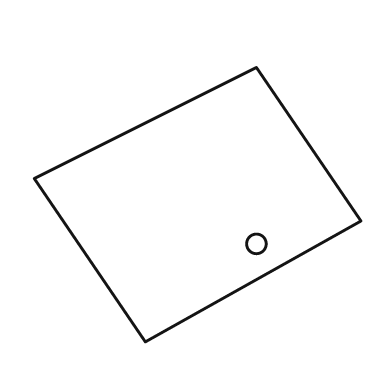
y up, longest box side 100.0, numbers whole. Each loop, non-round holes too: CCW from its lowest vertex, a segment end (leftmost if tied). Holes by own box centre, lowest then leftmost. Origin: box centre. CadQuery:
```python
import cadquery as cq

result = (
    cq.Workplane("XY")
    .moveTo(-16.0, -42.0)
    .lineTo(50.0, -5.0)
    .lineTo(18.0, 42.0)
    .lineTo(-50.0, 8.0)
    .close()
    .moveTo(18.0, -12.0)
    .circle(3.0)
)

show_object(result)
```